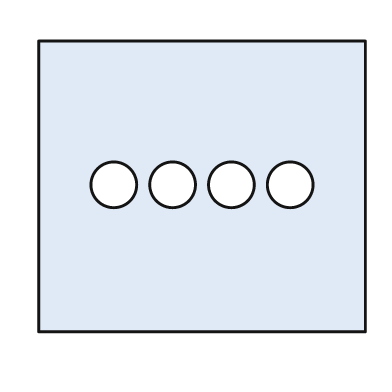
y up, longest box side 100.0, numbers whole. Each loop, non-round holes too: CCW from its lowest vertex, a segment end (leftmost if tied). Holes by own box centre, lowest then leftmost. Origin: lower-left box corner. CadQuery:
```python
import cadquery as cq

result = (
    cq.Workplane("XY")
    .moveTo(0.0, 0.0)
    .lineTo(100.0, 0.0)
    .lineTo(100.0, 89.0)
    .lineTo(0.0, 89.0)
    .close()
    .moveTo(23.0, 45.0)
    .circle(7.0)
    .moveTo(41.0, 45.0)
    .circle(7.0)
    .moveTo(59.0, 45.0)
    .circle(7.0)
    .moveTo(77.0, 45.0)
    .circle(7.0)
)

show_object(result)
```